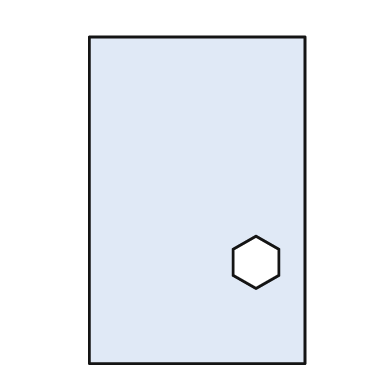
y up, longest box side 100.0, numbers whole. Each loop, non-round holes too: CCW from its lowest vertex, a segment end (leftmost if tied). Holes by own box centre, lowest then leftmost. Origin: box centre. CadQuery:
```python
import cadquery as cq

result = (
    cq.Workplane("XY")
    .moveTo(-33.0, -50.0)
    .lineTo(33.0, -50.0)
    .lineTo(33.0, 50.0)
    .lineTo(-33.0, 50.0)
    .close()
    .moveTo(18.0, -27.0)
    .lineTo(25.0, -23.0)
    .lineTo(25.0, -15.0)
    .lineTo(18.0, -11.0)
    .lineTo(11.0, -15.0)
    .lineTo(11.0, -23.0)
    .close()
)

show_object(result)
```